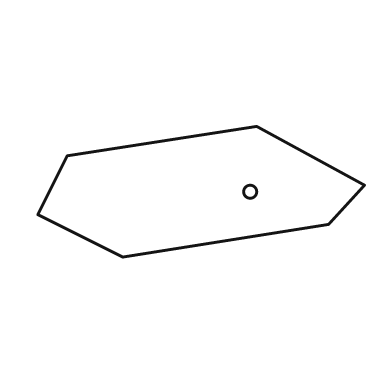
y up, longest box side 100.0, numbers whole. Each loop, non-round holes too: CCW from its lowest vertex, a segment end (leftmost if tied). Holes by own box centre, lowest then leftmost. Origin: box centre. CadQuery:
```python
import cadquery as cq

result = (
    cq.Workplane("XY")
    .moveTo(-24.0, -20.0)
    .lineTo(39.0, -10.0)
    .lineTo(50.0, 2.0)
    .lineTo(17.0, 20.0)
    .lineTo(-41.0, 11.0)
    .lineTo(-50.0, -7.0)
    .close()
    .moveTo(15.0, 0.0)
    .circle(2.0)
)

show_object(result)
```